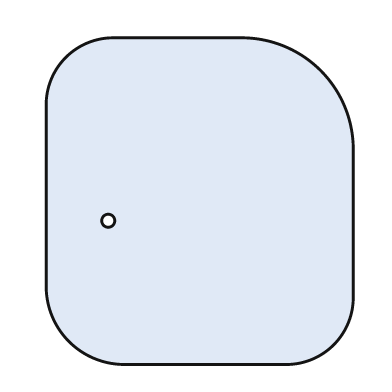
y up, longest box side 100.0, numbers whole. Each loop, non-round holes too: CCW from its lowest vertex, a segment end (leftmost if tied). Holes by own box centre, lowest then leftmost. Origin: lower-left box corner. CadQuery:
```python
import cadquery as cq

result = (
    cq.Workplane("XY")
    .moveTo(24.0, 0.0)
    .lineTo(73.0, 0.0)
    .threePointArc((88.0, 6.0), (94.0, 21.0))
    .lineTo(94.0, 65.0)
    .threePointArc((84.0, 90.0), (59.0, 100.0))
    .lineTo(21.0, 100.0)
    .threePointArc((6.0, 94.0), (0.0, 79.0))
    .lineTo(0.0, 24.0)
    .threePointArc((7.0, 7.0), (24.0, 0.0))
    .close()
    .moveTo(19.0, 44.0)
    .circle(2.0)
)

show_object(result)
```